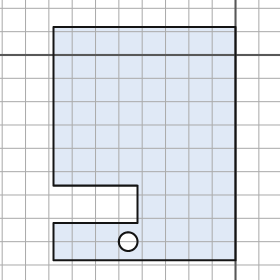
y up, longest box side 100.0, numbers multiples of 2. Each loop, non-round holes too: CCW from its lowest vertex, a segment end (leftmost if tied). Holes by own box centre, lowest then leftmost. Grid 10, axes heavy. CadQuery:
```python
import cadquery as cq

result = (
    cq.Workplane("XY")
    .moveTo(-78.0, -88.0)
    .lineTo(0.0, -88.0)
    .lineTo(0.0, 12.0)
    .lineTo(-78.0, 12.0)
    .lineTo(-78.0, -56.0)
    .lineTo(-42.0, -56.0)
    .lineTo(-42.0, -72.0)
    .lineTo(-78.0, -72.0)
    .close()
    .moveTo(-46.0, -80.0)
    .circle(4.0)
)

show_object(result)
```